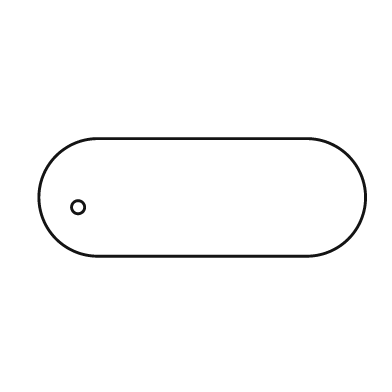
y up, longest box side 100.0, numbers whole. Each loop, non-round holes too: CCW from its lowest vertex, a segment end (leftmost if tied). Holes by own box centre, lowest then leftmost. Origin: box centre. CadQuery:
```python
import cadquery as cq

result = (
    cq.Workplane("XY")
    .moveTo(-32.0, -18.0)
    .lineTo(32.0, -18.0)
    .threePointArc((50.0, 0.0), (32.0, 18.0))
    .lineTo(-32.0, 18.0)
    .threePointArc((-50.0, 0.0), (-32.0, -18.0))
    .close()
    .moveTo(-38.0, -3.0)
    .circle(2.0)
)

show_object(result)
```